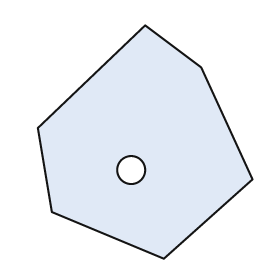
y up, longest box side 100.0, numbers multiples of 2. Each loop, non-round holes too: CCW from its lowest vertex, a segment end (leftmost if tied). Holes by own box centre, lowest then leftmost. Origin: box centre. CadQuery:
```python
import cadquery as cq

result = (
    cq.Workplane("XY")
    .moveTo(8.0, -50.0)
    .lineTo(46.0, -16.0)
    .lineTo(24.0, 32.0)
    .lineTo(0.0, 50.0)
    .lineTo(-46.0, 6.0)
    .lineTo(-40.0, -30.0)
    .close()
    .moveTo(-6.0, -12.0)
    .circle(6.0)
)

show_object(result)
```